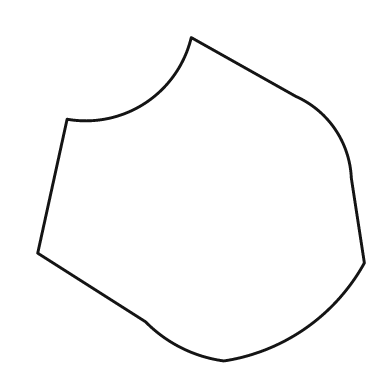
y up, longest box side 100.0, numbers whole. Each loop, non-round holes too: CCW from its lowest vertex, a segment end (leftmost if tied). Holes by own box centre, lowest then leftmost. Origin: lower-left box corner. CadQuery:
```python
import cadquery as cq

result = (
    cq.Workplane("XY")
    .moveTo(57.0, 0.0)
    .threePointArc((82.0, 10.0), (100.0, 30.0))
    .lineTo(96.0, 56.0)
    .threePointArc((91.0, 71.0), (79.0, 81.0))
    .lineTo(47.0, 99.0)
    .threePointArc((33.0, 79.0), (9.0, 74.0))
    .lineTo(0.0, 33.0)
    .lineTo(33.0, 12.0)
    .threePointArc((44.0, 4.0), (57.0, 0.0))
    .close()
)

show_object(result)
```